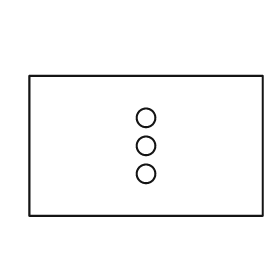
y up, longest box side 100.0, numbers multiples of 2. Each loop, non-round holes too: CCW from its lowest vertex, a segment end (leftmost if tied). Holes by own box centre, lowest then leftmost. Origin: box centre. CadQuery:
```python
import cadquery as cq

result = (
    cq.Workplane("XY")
    .moveTo(-50.0, -30.0)
    .lineTo(50.0, -30.0)
    .lineTo(50.0, 30.0)
    .lineTo(-50.0, 30.0)
    .close()
    .moveTo(0.0, -12.0)
    .circle(4.0)
    .moveTo(0.0, 0.0)
    .circle(4.0)
    .moveTo(0.0, 12.0)
    .circle(4.0)
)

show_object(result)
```